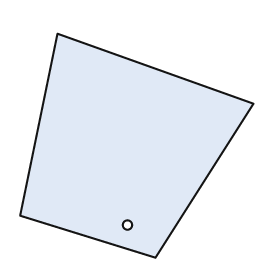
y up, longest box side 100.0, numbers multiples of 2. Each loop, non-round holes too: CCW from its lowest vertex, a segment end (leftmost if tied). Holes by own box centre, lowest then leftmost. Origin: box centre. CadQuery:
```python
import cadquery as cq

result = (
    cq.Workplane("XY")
    .moveTo(8.0, -48.0)
    .lineTo(50.0, 18.0)
    .lineTo(-34.0, 48.0)
    .lineTo(-50.0, -30.0)
    .close()
    .moveTo(-4.0, -34.0)
    .circle(2.0)
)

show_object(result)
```